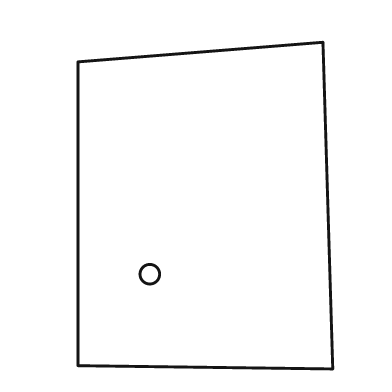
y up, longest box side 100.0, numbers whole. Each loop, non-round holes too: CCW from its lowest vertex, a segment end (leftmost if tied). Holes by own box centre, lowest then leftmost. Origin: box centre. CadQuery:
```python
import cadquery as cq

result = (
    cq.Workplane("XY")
    .moveTo(39.0, -50.0)
    .lineTo(36.0, 50.0)
    .lineTo(-39.0, 44.0)
    .lineTo(-39.0, -49.0)
    .close()
    .moveTo(-17.0, -21.0)
    .circle(3.0)
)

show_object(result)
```